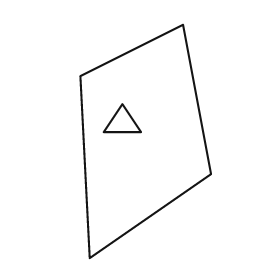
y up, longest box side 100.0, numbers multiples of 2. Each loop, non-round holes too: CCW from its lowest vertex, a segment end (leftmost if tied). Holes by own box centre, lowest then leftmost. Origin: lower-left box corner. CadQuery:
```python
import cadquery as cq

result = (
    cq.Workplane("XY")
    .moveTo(4.0, 0.0)
    .lineTo(56.0, 36.0)
    .lineTo(44.0, 100.0)
    .lineTo(0.0, 78.0)
    .close()
    .moveTo(10.0, 54.0)
    .lineTo(26.0, 54.0)
    .lineTo(18.0, 66.0)
    .close()
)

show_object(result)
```